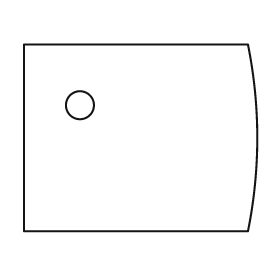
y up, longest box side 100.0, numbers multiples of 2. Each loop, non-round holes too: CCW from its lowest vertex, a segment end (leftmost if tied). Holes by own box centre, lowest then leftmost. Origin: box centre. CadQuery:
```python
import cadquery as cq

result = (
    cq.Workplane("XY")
    .moveTo(-50.0, -40.0)
    .lineTo(46.0, -40.0)
    .threePointArc((50.0, 0.0), (46.0, 40.0))
    .lineTo(-50.0, 40.0)
    .close()
    .moveTo(-26.0, 14.0)
    .circle(6.0)
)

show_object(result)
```